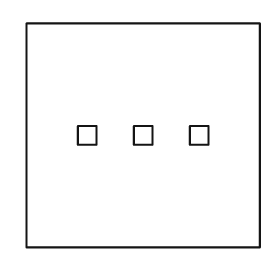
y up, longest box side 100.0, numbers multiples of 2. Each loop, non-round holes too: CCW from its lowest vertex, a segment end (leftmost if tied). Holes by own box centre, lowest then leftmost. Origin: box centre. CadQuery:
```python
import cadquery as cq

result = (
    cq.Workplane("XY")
    .moveTo(-50.0, -48.0)
    .lineTo(50.0, -48.0)
    .lineTo(50.0, 48.0)
    .lineTo(-50.0, 48.0)
    .close()
    .moveTo(-28.0, -4.0)
    .lineTo(-20.0, -4.0)
    .lineTo(-20.0, 4.0)
    .lineTo(-28.0, 4.0)
    .close()
    .moveTo(-4.0, -4.0)
    .lineTo(4.0, -4.0)
    .lineTo(4.0, 4.0)
    .lineTo(-4.0, 4.0)
    .close()
    .moveTo(20.0, -4.0)
    .lineTo(28.0, -4.0)
    .lineTo(28.0, 4.0)
    .lineTo(20.0, 4.0)
    .close()
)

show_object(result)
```